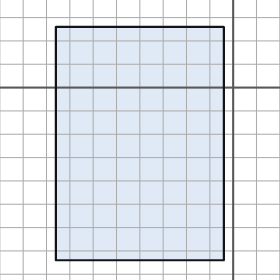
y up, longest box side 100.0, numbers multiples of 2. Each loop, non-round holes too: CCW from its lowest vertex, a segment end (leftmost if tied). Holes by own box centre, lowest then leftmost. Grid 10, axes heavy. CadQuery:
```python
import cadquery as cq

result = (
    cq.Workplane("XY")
    .moveTo(-76.0, -74.0)
    .lineTo(-4.0, -74.0)
    .lineTo(-4.0, 26.0)
    .lineTo(-76.0, 26.0)
    .close()
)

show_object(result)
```